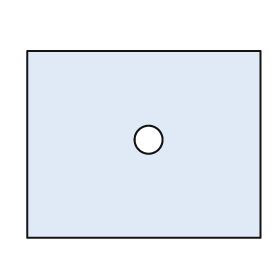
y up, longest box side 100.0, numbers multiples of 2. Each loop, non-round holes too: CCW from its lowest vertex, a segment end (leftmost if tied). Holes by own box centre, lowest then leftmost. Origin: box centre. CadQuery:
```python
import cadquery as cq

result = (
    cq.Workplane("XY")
    .moveTo(-50.0, -40.0)
    .lineTo(50.0, -40.0)
    .lineTo(50.0, 40.0)
    .lineTo(-50.0, 40.0)
    .close()
    .moveTo(2.0, 2.0)
    .circle(6.0)
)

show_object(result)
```